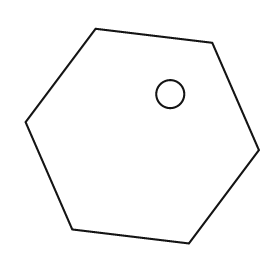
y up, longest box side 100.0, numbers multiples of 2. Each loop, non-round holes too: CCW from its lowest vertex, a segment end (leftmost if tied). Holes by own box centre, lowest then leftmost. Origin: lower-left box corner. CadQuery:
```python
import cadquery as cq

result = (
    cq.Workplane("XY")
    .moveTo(70.0, 0.0)
    .lineTo(100.0, 40.0)
    .lineTo(80.0, 86.0)
    .lineTo(30.0, 92.0)
    .lineTo(0.0, 52.0)
    .lineTo(20.0, 6.0)
    .close()
    .moveTo(62.0, 64.0)
    .circle(6.0)
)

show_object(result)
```